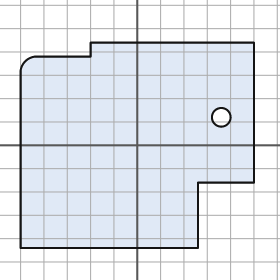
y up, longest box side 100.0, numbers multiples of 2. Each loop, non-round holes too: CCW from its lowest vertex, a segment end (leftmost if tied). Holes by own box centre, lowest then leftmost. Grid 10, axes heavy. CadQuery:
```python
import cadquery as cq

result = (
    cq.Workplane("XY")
    .moveTo(-50.0, -44.0)
    .lineTo(26.0, -44.0)
    .lineTo(26.0, -16.0)
    .lineTo(50.0, -16.0)
    .lineTo(50.0, 44.0)
    .lineTo(-20.0, 44.0)
    .lineTo(-20.0, 38.0)
    .lineTo(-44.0, 38.0)
    .threePointArc((-48.0, 36.0), (-50.0, 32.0))
    .close()
    .moveTo(36.0, 12.0)
    .circle(4.0)
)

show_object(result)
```